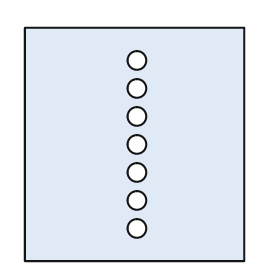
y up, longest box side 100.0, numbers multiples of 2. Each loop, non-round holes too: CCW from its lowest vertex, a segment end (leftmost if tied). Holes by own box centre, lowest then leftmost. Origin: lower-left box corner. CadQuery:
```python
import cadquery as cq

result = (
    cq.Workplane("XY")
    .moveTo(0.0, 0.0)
    .lineTo(94.0, 0.0)
    .lineTo(94.0, 100.0)
    .lineTo(0.0, 100.0)
    .close()
    .moveTo(48.0, 14.0)
    .circle(4.0)
    .moveTo(48.0, 26.0)
    .circle(4.0)
    .moveTo(48.0, 38.0)
    .circle(4.0)
    .moveTo(48.0, 50.0)
    .circle(4.0)
    .moveTo(48.0, 62.0)
    .circle(4.0)
    .moveTo(48.0, 74.0)
    .circle(4.0)
    .moveTo(48.0, 86.0)
    .circle(4.0)
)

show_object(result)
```